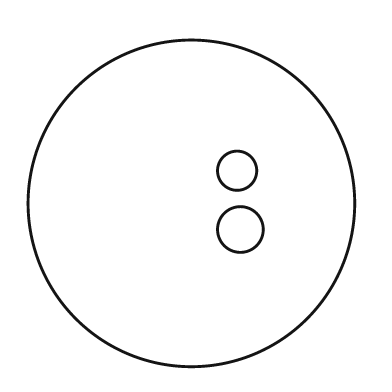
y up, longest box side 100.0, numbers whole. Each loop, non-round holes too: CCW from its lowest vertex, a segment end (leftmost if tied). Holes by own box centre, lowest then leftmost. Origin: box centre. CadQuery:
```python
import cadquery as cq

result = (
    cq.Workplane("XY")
    .moveTo(0.0, 0.0)
    .circle(50.0)
    .moveTo(15.0, -8.0)
    .circle(7.0)
    .moveTo(14.0, 10.0)
    .circle(6.0)
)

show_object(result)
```